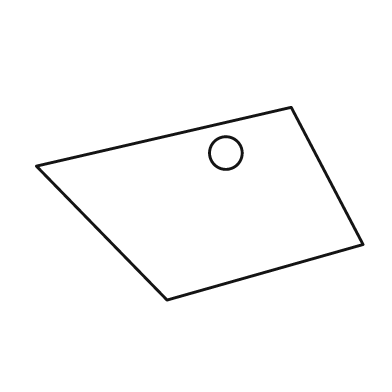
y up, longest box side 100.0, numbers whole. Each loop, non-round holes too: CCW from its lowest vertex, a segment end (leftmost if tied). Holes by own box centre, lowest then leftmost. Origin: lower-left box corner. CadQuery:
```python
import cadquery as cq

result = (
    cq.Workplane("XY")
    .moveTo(40.0, 0.0)
    .lineTo(100.0, 17.0)
    .lineTo(78.0, 59.0)
    .lineTo(0.0, 41.0)
    .close()
    .moveTo(58.0, 45.0)
    .circle(5.0)
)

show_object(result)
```